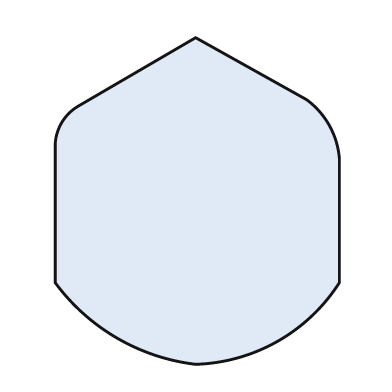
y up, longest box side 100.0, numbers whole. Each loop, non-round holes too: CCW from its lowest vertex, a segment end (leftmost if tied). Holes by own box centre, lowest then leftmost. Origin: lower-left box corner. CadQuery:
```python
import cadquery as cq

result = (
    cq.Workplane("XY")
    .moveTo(43.0, 0.0)
    .threePointArc((68.0, 7.0), (87.0, 25.0))
    .lineTo(87.0, 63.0)
    .threePointArc((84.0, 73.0), (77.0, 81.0))
    .lineTo(43.0, 100.0)
    .lineTo(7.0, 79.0)
    .threePointArc((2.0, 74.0), (0.0, 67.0))
    .lineTo(0.0, 25.0)
    .threePointArc((19.0, 8.0), (43.0, 0.0))
    .close()
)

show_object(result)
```